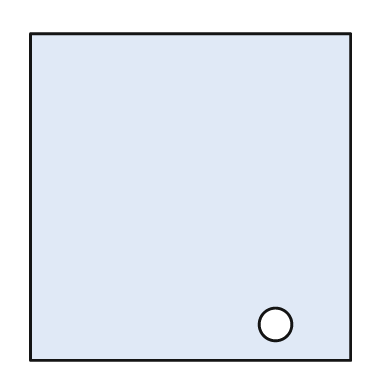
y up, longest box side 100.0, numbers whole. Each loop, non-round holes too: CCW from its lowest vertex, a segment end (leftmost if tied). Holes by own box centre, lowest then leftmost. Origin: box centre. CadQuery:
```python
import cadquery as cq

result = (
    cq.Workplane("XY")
    .moveTo(-49.0, -50.0)
    .lineTo(49.0, -50.0)
    .lineTo(49.0, 50.0)
    .lineTo(-49.0, 50.0)
    .close()
    .moveTo(26.0, -39.0)
    .circle(5.0)
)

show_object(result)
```